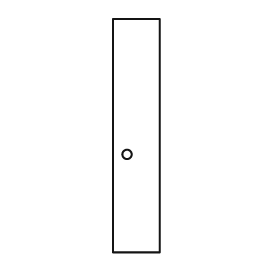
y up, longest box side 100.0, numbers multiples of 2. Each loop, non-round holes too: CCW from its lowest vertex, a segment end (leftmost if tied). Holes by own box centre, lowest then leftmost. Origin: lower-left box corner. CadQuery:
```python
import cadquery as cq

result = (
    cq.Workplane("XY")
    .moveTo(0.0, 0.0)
    .lineTo(20.0, 0.0)
    .lineTo(20.0, 100.0)
    .lineTo(0.0, 100.0)
    .close()
    .moveTo(6.0, 42.0)
    .circle(2.0)
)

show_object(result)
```